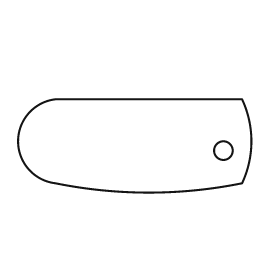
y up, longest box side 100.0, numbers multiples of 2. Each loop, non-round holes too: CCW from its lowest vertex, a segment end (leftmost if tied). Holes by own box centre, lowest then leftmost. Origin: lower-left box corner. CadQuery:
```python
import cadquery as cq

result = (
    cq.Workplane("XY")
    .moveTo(16.0, 4.0)
    .threePointArc((56.0, 0.0), (96.0, 4.0))
    .threePointArc((100.0, 22.0), (96.0, 40.0))
    .lineTo(16.0, 40.0)
    .threePointArc((0.0, 22.0), (16.0, 4.0))
    .close()
    .moveTo(88.0, 18.0)
    .circle(4.0)
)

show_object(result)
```